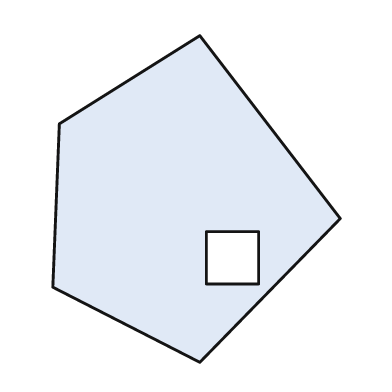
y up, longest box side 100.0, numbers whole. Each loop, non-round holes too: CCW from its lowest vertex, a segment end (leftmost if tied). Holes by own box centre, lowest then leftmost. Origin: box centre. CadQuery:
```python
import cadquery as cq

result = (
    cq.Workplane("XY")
    .moveTo(1.0, -50.0)
    .lineTo(44.0, -6.0)
    .lineTo(1.0, 50.0)
    .lineTo(-42.0, 23.0)
    .lineTo(-44.0, -27.0)
    .close()
    .moveTo(3.0, -26.0)
    .lineTo(19.0, -26.0)
    .lineTo(19.0, -10.0)
    .lineTo(3.0, -10.0)
    .close()
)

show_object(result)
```